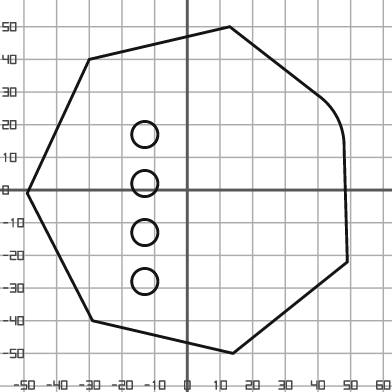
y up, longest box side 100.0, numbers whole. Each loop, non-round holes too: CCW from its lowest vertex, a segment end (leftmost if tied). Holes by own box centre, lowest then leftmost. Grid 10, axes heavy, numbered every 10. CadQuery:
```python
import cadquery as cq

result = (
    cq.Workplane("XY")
    .moveTo(14.0, -50.0)
    .lineTo(49.0, -22.0)
    .lineTo(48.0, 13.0)
    .threePointArc((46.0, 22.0), (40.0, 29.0))
    .lineTo(13.0, 50.0)
    .lineTo(-30.0, 40.0)
    .lineTo(-49.0, -1.0)
    .lineTo(-29.0, -40.0)
    .close()
    .moveTo(-13.0, -28.0)
    .circle(4.0)
    .moveTo(-13.0, -13.0)
    .circle(4.0)
    .moveTo(-13.0, 2.0)
    .circle(4.0)
    .moveTo(-13.0, 17.0)
    .circle(4.0)
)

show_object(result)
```